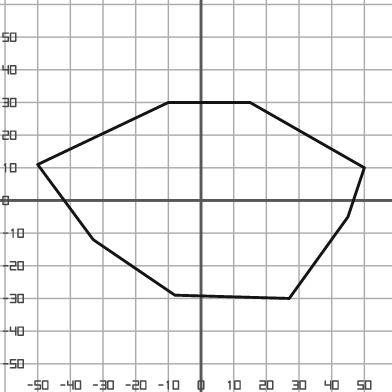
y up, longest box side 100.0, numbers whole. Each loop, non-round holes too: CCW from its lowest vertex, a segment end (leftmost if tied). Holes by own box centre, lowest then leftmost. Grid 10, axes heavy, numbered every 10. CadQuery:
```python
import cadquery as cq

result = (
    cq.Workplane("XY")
    .moveTo(27.0, -30.0)
    .lineTo(45.0, -5.0)
    .lineTo(50.0, 10.0)
    .lineTo(15.0, 30.0)
    .lineTo(-10.0, 30.0)
    .lineTo(-50.0, 11.0)
    .lineTo(-33.0, -12.0)
    .lineTo(-8.0, -29.0)
    .close()
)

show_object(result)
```